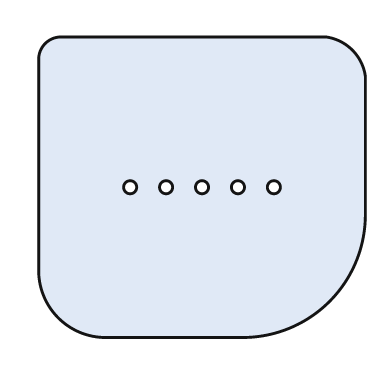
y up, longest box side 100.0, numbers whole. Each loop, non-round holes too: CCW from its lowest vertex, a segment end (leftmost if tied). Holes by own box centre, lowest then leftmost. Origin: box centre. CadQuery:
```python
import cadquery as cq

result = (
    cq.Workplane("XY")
    .moveTo(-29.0, -46.0)
    .lineTo(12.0, -46.0)
    .threePointArc((39.0, -35.0), (50.0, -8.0))
    .lineTo(50.0, 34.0)
    .threePointArc((46.0, 42.0), (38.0, 46.0))
    .lineTo(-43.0, 46.0)
    .threePointArc((-48.0, 44.0), (-50.0, 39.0))
    .lineTo(-50.0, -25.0)
    .threePointArc((-44.0, -40.0), (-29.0, -46.0))
    .close()
    .moveTo(-22.0, 0.0)
    .circle(2.0)
    .moveTo(-11.0, 0.0)
    .circle(2.0)
    .moveTo(0.0, 0.0)
    .circle(2.0)
    .moveTo(11.0, 0.0)
    .circle(2.0)
    .moveTo(22.0, 0.0)
    .circle(2.0)
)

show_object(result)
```